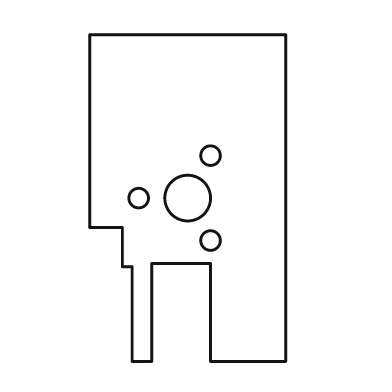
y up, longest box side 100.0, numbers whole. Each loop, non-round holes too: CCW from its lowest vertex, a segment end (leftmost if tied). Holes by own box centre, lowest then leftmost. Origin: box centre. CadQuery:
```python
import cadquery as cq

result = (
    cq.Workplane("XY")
    .moveTo(-17.0, -50.0)
    .lineTo(-11.0, -50.0)
    .lineTo(-11.0, -20.0)
    .lineTo(7.0, -20.0)
    .lineTo(7.0, -50.0)
    .lineTo(30.0, -50.0)
    .lineTo(30.0, 50.0)
    .lineTo(-30.0, 50.0)
    .lineTo(-30.0, -9.0)
    .lineTo(-20.0, -9.0)
    .lineTo(-20.0, -21.0)
    .lineTo(-17.0, -21.0)
    .close()
    .moveTo(7.0, -13.0)
    .circle(3.0)
    .moveTo(-15.0, 0.0)
    .circle(3.0)
    .moveTo(0.0, 0.0)
    .circle(7.0)
    .moveTo(7.0, 13.0)
    .circle(3.0)
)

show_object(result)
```